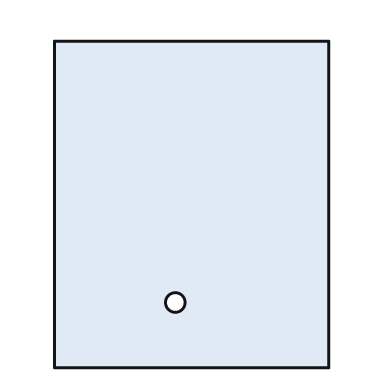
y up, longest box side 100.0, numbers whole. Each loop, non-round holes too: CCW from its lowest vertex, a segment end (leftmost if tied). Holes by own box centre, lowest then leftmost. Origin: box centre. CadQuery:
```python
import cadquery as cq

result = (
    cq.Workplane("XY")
    .moveTo(-42.0, -50.0)
    .lineTo(42.0, -50.0)
    .lineTo(42.0, 50.0)
    .lineTo(-42.0, 50.0)
    .close()
    .moveTo(-5.0, -30.0)
    .circle(3.0)
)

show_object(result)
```